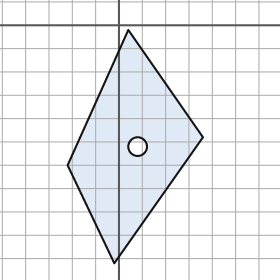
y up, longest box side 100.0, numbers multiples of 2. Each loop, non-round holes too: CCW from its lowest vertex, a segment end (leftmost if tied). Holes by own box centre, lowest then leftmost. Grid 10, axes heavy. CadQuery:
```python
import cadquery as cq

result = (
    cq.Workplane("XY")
    .moveTo(-2.0, -102.0)
    .lineTo(36.0, -48.0)
    .lineTo(4.0, -2.0)
    .lineTo(-22.0, -60.0)
    .close()
    .moveTo(8.0, -52.0)
    .circle(4.0)
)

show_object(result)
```